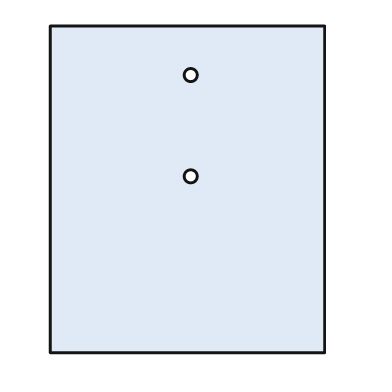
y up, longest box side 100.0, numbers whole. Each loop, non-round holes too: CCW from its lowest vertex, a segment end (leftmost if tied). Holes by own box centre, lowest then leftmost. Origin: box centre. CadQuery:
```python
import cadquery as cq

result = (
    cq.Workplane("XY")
    .moveTo(-42.0, -50.0)
    .lineTo(42.0, -50.0)
    .lineTo(42.0, 50.0)
    .lineTo(-42.0, 50.0)
    .close()
    .moveTo(1.0, 4.0)
    .circle(2.0)
    .moveTo(1.0, 35.0)
    .circle(2.0)
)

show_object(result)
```